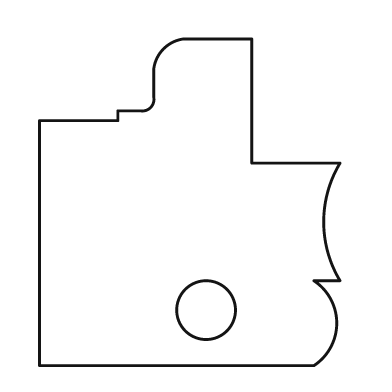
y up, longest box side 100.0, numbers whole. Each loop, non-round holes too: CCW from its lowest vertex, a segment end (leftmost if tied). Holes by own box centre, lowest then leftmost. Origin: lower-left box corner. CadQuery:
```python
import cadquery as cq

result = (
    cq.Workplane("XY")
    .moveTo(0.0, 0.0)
    .lineTo(84.0, 0.0)
    .threePointArc((91.0, 13.0), (84.0, 26.0))
    .lineTo(92.0, 26.0)
    .threePointArc((87.0, 44.0), (92.0, 62.0))
    .lineTo(65.0, 62.0)
    .lineTo(65.0, 100.0)
    .lineTo(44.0, 100.0)
    .threePointArc((38.0, 97.0), (35.0, 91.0))
    .lineTo(35.0, 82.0)
    .threePointArc((34.0, 79.0), (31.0, 78.0))
    .lineTo(24.0, 78.0)
    .lineTo(24.0, 75.0)
    .lineTo(0.0, 75.0)
    .close()
    .moveTo(51.0, 17.0)
    .circle(9.0)
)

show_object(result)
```